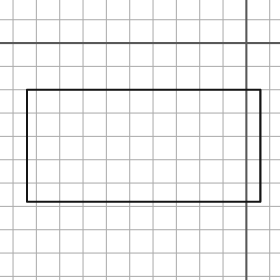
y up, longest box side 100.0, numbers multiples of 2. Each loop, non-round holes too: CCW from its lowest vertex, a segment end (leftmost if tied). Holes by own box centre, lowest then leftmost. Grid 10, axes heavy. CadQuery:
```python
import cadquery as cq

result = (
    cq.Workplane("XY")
    .moveTo(-94.0, -68.0)
    .lineTo(6.0, -68.0)
    .lineTo(6.0, -20.0)
    .lineTo(-94.0, -20.0)
    .close()
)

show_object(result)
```